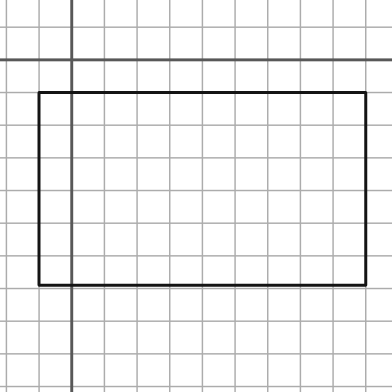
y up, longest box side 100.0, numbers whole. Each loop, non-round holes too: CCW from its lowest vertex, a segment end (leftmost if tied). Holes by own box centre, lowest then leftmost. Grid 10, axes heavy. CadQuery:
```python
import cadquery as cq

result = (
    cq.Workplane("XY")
    .moveTo(-10.0, -69.0)
    .lineTo(90.0, -69.0)
    .lineTo(90.0, -10.0)
    .lineTo(-10.0, -10.0)
    .close()
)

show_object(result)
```